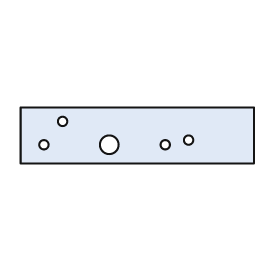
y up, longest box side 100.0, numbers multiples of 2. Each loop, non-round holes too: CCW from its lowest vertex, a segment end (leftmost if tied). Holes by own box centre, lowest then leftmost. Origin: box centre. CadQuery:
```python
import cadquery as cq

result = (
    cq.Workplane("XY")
    .moveTo(-50.0, -12.0)
    .lineTo(50.0, -12.0)
    .lineTo(50.0, 12.0)
    .lineTo(-50.0, 12.0)
    .close()
    .moveTo(-40.0, -4.0)
    .circle(2.0)
    .moveTo(-12.0, -4.0)
    .circle(4.0)
    .moveTo(12.0, -4.0)
    .circle(2.0)
    .moveTo(22.0, -2.0)
    .circle(2.0)
    .moveTo(-32.0, 6.0)
    .circle(2.0)
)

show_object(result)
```